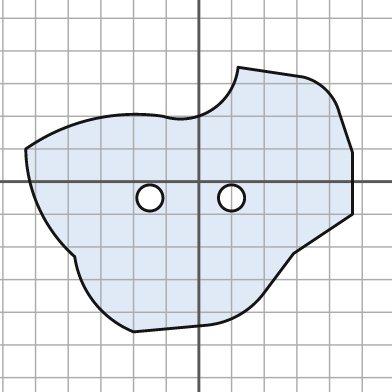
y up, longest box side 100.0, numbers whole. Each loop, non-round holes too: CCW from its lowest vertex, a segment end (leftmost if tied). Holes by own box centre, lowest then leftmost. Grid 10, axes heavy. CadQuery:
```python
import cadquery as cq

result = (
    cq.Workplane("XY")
    .moveTo(-20.0, -46.0)
    .lineTo(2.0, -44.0)
    .threePointArc((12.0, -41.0), (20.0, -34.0))
    .lineTo(29.0, -22.0)
    .lineTo(47.0, -10.0)
    .lineTo(47.0, 9.0)
    .lineTo(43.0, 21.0)
    .threePointArc((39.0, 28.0), (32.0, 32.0))
    .lineTo(12.0, 35.0)
    .threePointArc((4.0, 22.0), (-11.0, 20.0))
    .threePointArc((-33.0, 19.0), (-53.0, 10.0))
    .threePointArc((-49.0, -8.0), (-38.0, -23.0))
    .threePointArc((-32.0, -37.0), (-20.0, -46.0))
    .close()
    .moveTo(-15.0, -5.0)
    .circle(4.0)
    .moveTo(10.0, -5.0)
    .circle(4.0)
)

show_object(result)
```